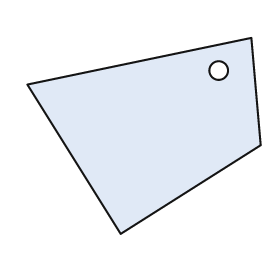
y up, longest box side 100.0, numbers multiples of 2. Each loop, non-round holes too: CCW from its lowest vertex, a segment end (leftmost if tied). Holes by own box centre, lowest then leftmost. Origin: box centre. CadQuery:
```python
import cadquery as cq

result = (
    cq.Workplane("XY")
    .moveTo(-10.0, -42.0)
    .lineTo(50.0, -4.0)
    .lineTo(46.0, 42.0)
    .lineTo(-50.0, 22.0)
    .close()
    .moveTo(32.0, 28.0)
    .circle(4.0)
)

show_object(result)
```